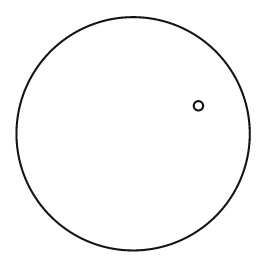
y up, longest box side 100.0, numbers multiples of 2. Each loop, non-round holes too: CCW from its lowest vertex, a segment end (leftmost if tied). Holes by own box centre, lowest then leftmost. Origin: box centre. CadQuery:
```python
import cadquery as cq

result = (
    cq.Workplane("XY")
    .moveTo(0.0, 0.0)
    .circle(50.0)
    .moveTo(28.0, 12.0)
    .circle(2.0)
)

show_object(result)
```